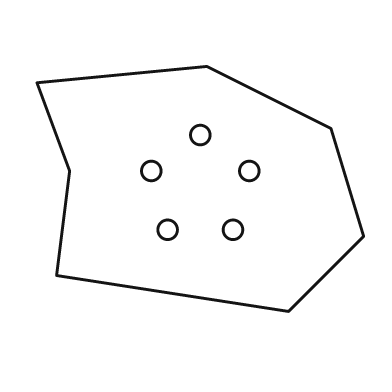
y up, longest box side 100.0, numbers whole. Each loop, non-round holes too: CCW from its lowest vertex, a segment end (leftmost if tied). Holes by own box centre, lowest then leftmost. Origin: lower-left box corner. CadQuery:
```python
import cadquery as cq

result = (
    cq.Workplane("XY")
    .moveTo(77.0, 0.0)
    .lineTo(100.0, 23.0)
    .lineTo(90.0, 56.0)
    .lineTo(52.0, 75.0)
    .lineTo(0.0, 70.0)
    .lineTo(10.0, 43.0)
    .lineTo(6.0, 11.0)
    .close()
    .moveTo(40.0, 25.0)
    .circle(3.0)
    .moveTo(60.0, 25.0)
    .circle(3.0)
    .moveTo(35.0, 43.0)
    .circle(3.0)
    .moveTo(65.0, 43.0)
    .circle(3.0)
    .moveTo(50.0, 54.0)
    .circle(3.0)
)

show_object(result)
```